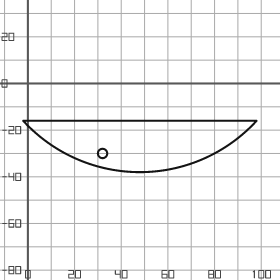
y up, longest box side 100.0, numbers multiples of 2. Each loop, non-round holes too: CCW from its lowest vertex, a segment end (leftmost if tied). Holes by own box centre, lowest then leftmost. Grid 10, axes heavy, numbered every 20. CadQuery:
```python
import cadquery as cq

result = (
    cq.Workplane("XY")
    .moveTo(-2.0, -16.0)
    .threePointArc((48.0, -38.0), (98.0, -16.0))
    .close()
    .moveTo(32.0, -30.0)
    .circle(2.0)
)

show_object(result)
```